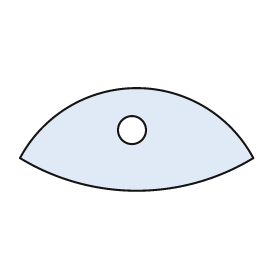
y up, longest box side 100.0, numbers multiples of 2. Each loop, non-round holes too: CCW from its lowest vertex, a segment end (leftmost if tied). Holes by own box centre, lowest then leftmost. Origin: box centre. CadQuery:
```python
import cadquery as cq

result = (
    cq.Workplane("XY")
    .moveTo(-50.0, -8.0)
    .threePointArc((0.0, -22.0), (50.0, -8.0))
    .threePointArc((0.0, 22.0), (-50.0, -8.0))
    .close()
    .moveTo(-2.0, 4.0)
    .circle(6.0)
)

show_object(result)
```